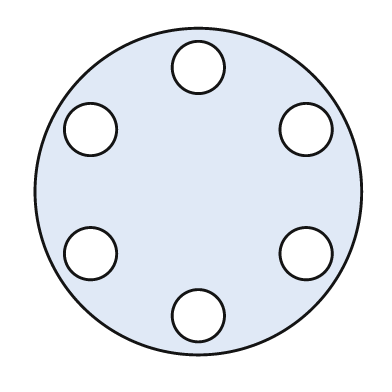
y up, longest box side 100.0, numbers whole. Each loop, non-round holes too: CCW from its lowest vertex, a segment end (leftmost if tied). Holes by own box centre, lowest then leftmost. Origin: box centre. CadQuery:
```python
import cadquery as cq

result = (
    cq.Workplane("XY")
    .moveTo(0.0, 0.0)
    .circle(50.0)
    .moveTo(0.0, -38.0)
    .circle(8.0)
    .moveTo(-33.0, -19.0)
    .circle(8.0)
    .moveTo(33.0, -19.0)
    .circle(8.0)
    .moveTo(-33.0, 19.0)
    .circle(8.0)
    .moveTo(33.0, 19.0)
    .circle(8.0)
    .moveTo(0.0, 38.0)
    .circle(8.0)
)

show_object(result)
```